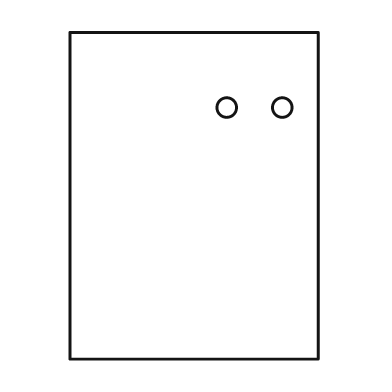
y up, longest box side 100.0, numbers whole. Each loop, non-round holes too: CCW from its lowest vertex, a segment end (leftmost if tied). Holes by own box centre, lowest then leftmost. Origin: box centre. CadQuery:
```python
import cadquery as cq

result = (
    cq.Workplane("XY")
    .moveTo(-38.0, -50.0)
    .lineTo(38.0, -50.0)
    .lineTo(38.0, 50.0)
    .lineTo(-38.0, 50.0)
    .close()
    .moveTo(10.0, 27.0)
    .circle(3.0)
    .moveTo(27.0, 27.0)
    .circle(3.0)
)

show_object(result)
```